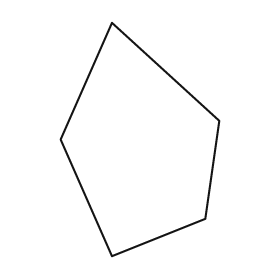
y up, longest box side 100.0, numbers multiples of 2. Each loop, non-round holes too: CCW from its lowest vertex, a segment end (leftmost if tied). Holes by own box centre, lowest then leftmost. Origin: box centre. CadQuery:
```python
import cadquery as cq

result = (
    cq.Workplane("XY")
    .moveTo(-12.0, -50.0)
    .lineTo(28.0, -34.0)
    .lineTo(34.0, 8.0)
    .lineTo(-12.0, 50.0)
    .lineTo(-34.0, 0.0)
    .close()
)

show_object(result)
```